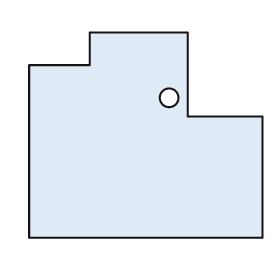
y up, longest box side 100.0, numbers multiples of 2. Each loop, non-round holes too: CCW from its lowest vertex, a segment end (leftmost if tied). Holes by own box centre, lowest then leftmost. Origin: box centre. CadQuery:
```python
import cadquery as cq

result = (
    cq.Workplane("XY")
    .moveTo(-50.0, -44.0)
    .lineTo(50.0, -44.0)
    .lineTo(50.0, 8.0)
    .lineTo(18.0, 8.0)
    .lineTo(18.0, 44.0)
    .lineTo(-24.0, 44.0)
    .lineTo(-24.0, 30.0)
    .lineTo(-50.0, 30.0)
    .close()
    .moveTo(10.0, 16.0)
    .circle(4.0)
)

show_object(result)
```